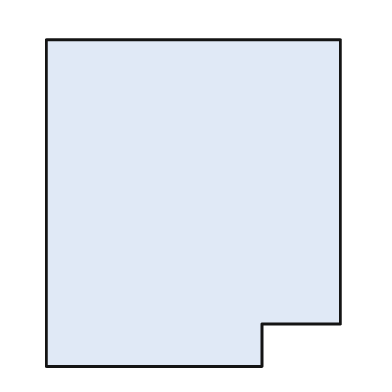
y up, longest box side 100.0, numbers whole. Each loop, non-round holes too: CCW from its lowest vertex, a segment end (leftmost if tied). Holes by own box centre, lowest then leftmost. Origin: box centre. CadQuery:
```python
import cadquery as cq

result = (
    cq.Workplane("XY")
    .moveTo(-45.0, -50.0)
    .lineTo(21.0, -50.0)
    .lineTo(21.0, -37.0)
    .lineTo(45.0, -37.0)
    .lineTo(45.0, 50.0)
    .lineTo(-45.0, 50.0)
    .close()
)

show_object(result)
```